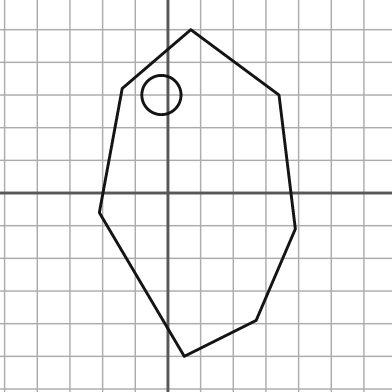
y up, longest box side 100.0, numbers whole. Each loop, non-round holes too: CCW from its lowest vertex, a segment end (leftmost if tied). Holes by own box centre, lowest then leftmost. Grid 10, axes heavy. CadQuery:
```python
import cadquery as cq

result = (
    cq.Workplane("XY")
    .moveTo(5.0, -50.0)
    .lineTo(27.0, -39.0)
    .lineTo(39.0, -11.0)
    .lineTo(34.0, 30.0)
    .lineTo(7.0, 50.0)
    .lineTo(-14.0, 32.0)
    .lineTo(-21.0, -6.0)
    .close()
    .moveTo(-2.0, 30.0)
    .circle(6.0)
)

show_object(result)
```